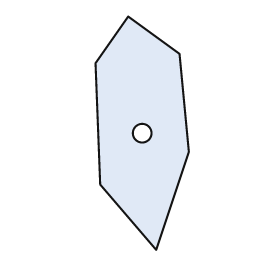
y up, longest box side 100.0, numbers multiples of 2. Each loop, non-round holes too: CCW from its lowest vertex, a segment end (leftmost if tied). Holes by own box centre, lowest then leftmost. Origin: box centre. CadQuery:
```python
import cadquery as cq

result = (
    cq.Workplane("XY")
    .moveTo(6.0, -50.0)
    .lineTo(20.0, -8.0)
    .lineTo(16.0, 34.0)
    .lineTo(-6.0, 50.0)
    .lineTo(-20.0, 30.0)
    .lineTo(-18.0, -22.0)
    .close()
    .moveTo(0.0, 0.0)
    .circle(4.0)
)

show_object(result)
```